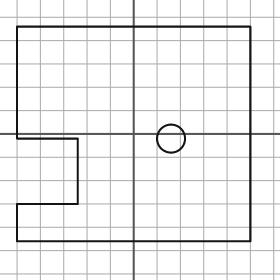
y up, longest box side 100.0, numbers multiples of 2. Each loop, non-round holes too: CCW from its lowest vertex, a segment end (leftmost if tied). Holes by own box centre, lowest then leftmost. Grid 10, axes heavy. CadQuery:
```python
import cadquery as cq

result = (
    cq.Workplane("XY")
    .moveTo(-50.0, -46.0)
    .lineTo(50.0, -46.0)
    .lineTo(50.0, 46.0)
    .lineTo(-50.0, 46.0)
    .lineTo(-50.0, -2.0)
    .lineTo(-24.0, -2.0)
    .lineTo(-24.0, -30.0)
    .lineTo(-50.0, -30.0)
    .close()
    .moveTo(16.0, -2.0)
    .circle(6.0)
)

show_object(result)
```